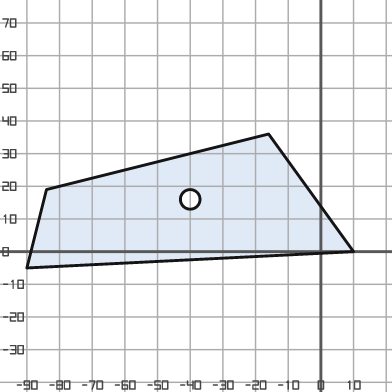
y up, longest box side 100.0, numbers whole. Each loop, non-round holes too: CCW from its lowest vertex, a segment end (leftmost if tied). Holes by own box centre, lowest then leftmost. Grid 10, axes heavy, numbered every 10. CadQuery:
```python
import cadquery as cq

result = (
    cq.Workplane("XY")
    .moveTo(-90.0, -5.0)
    .lineTo(10.0, 0.0)
    .lineTo(-16.0, 36.0)
    .lineTo(-84.0, 19.0)
    .close()
    .moveTo(-40.0, 16.0)
    .circle(3.0)
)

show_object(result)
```